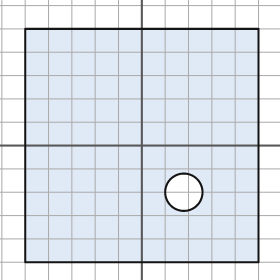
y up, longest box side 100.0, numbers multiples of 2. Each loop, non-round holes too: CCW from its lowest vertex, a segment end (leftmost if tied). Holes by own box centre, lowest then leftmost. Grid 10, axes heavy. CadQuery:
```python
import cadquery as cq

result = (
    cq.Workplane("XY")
    .moveTo(-50.0, -50.0)
    .lineTo(50.0, -50.0)
    .lineTo(50.0, 50.0)
    .lineTo(-50.0, 50.0)
    .close()
    .moveTo(18.0, -20.0)
    .circle(8.0)
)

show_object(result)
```